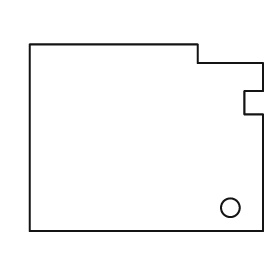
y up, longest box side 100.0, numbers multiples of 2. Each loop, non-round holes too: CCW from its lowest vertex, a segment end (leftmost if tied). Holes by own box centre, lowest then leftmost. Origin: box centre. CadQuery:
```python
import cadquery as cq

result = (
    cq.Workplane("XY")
    .moveTo(-50.0, -40.0)
    .lineTo(50.0, -40.0)
    .lineTo(50.0, 10.0)
    .lineTo(42.0, 10.0)
    .lineTo(42.0, 20.0)
    .lineTo(50.0, 20.0)
    .lineTo(50.0, 32.0)
    .lineTo(22.0, 32.0)
    .lineTo(22.0, 40.0)
    .lineTo(-50.0, 40.0)
    .close()
    .moveTo(36.0, -30.0)
    .circle(4.0)
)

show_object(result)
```